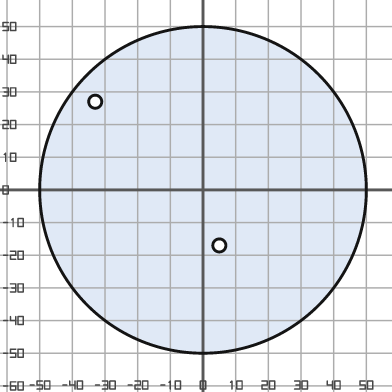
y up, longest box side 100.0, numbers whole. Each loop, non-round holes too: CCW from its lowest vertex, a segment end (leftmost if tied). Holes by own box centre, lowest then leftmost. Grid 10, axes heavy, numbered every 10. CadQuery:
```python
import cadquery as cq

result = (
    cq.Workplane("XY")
    .moveTo(0.0, 0.0)
    .circle(50.0)
    .moveTo(5.0, -17.0)
    .circle(2.0)
    .moveTo(-33.0, 27.0)
    .circle(2.0)
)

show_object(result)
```